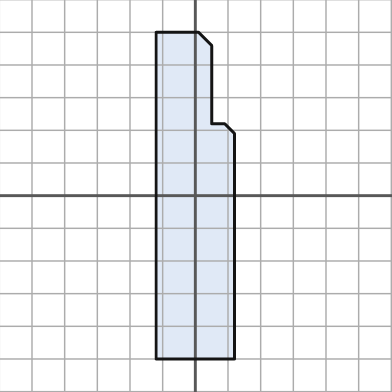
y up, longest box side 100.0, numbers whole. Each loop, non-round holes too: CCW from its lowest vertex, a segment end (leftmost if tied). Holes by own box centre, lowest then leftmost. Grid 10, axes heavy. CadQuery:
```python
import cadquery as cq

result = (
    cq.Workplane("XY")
    .moveTo(-12.0, -50.0)
    .lineTo(12.0, -50.0)
    .lineTo(12.0, 19.0)
    .lineTo(9.0, 22.0)
    .lineTo(5.0, 22.0)
    .lineTo(5.0, 46.0)
    .lineTo(1.0, 50.0)
    .lineTo(-12.0, 50.0)
    .close()
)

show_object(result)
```